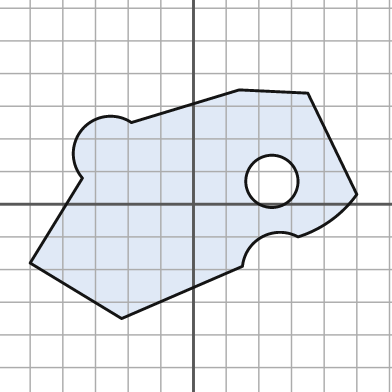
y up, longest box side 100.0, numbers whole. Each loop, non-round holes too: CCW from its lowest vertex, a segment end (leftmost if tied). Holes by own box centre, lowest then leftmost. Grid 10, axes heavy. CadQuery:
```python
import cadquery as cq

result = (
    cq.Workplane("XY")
    .moveTo(-22.0, -35.0)
    .lineTo(15.0, -19.0)
    .threePointArc((21.0, -10.0), (32.0, -10.0))
    .threePointArc((42.0, -5.0), (50.0, 3.0))
    .lineTo(35.0, 34.0)
    .lineTo(14.0, 35.0)
    .lineTo(-19.0, 25.0)
    .threePointArc((-34.0, 23.0), (-34.0, 8.0))
    .lineTo(-50.0, -18.0)
    .close()
    .moveTo(24.0, 7.0)
    .circle(8.0)
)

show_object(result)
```